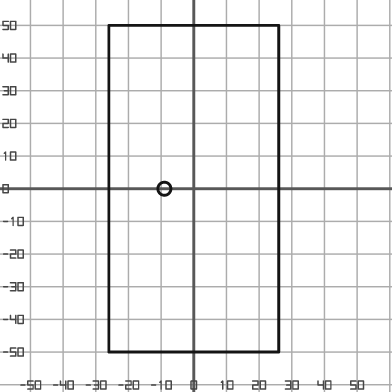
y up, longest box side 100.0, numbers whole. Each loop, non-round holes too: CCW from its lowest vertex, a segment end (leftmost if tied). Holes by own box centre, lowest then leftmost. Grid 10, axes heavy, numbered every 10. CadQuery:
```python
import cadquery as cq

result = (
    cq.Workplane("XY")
    .moveTo(-26.0, -50.0)
    .lineTo(26.0, -50.0)
    .lineTo(26.0, 50.0)
    .lineTo(-26.0, 50.0)
    .close()
    .moveTo(-9.0, 0.0)
    .circle(2.0)
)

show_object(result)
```